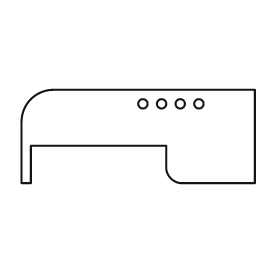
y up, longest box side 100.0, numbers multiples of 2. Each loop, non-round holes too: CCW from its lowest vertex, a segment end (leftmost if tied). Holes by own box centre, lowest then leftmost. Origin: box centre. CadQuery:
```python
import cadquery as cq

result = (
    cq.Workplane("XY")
    .moveTo(-50.0, -20.0)
    .lineTo(-46.0, -20.0)
    .lineTo(-46.0, -4.0)
    .lineTo(12.0, -4.0)
    .lineTo(12.0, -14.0)
    .threePointArc((14.0, -18.0), (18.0, -20.0))
    .lineTo(50.0, -20.0)
    .lineTo(50.0, 20.0)
    .lineTo(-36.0, 20.0)
    .threePointArc((-46.0, 16.0), (-50.0, 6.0))
    .close()
    .moveTo(2.0, 14.0)
    .circle(2.0)
    .moveTo(10.0, 14.0)
    .circle(2.0)
    .moveTo(18.0, 14.0)
    .circle(2.0)
    .moveTo(26.0, 14.0)
    .circle(2.0)
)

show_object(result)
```